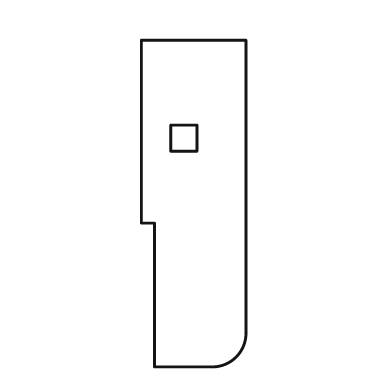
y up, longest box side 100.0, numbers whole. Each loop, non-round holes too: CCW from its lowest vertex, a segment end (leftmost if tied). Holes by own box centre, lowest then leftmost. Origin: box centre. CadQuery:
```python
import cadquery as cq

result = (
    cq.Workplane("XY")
    .moveTo(-12.0, -50.0)
    .lineTo(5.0, -50.0)
    .threePointArc((13.0, -47.0), (16.0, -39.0))
    .lineTo(16.0, 50.0)
    .lineTo(-16.0, 50.0)
    .lineTo(-16.0, -6.0)
    .lineTo(-12.0, -6.0)
    .close()
    .moveTo(-7.0, 16.0)
    .lineTo(1.0, 16.0)
    .lineTo(1.0, 24.0)
    .lineTo(-7.0, 24.0)
    .close()
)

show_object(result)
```